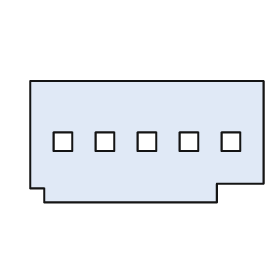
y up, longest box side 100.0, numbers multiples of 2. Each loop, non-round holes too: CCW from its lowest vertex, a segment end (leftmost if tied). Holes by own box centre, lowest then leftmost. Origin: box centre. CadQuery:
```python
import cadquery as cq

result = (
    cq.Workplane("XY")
    .moveTo(-44.0, -26.0)
    .lineTo(30.0, -26.0)
    .lineTo(30.0, -18.0)
    .lineTo(50.0, -18.0)
    .lineTo(50.0, 26.0)
    .lineTo(-50.0, 26.0)
    .lineTo(-50.0, -20.0)
    .lineTo(-44.0, -20.0)
    .close()
    .moveTo(-40.0, -4.0)
    .lineTo(-32.0, -4.0)
    .lineTo(-32.0, 4.0)
    .lineTo(-40.0, 4.0)
    .close()
    .moveTo(-22.0, -4.0)
    .lineTo(-14.0, -4.0)
    .lineTo(-14.0, 4.0)
    .lineTo(-22.0, 4.0)
    .close()
    .moveTo(-4.0, -4.0)
    .lineTo(4.0, -4.0)
    .lineTo(4.0, 4.0)
    .lineTo(-4.0, 4.0)
    .close()
    .moveTo(14.0, -4.0)
    .lineTo(22.0, -4.0)
    .lineTo(22.0, 4.0)
    .lineTo(14.0, 4.0)
    .close()
    .moveTo(32.0, -4.0)
    .lineTo(40.0, -4.0)
    .lineTo(40.0, 4.0)
    .lineTo(32.0, 4.0)
    .close()
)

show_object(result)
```